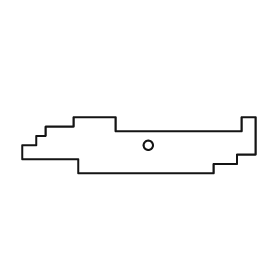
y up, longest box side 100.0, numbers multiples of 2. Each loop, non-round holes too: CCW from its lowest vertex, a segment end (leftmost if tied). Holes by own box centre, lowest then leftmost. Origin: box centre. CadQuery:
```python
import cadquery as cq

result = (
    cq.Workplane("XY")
    .moveTo(-26.0, -12.0)
    .lineTo(32.0, -12.0)
    .lineTo(32.0, -8.0)
    .lineTo(42.0, -8.0)
    .lineTo(42.0, -4.0)
    .lineTo(50.0, -4.0)
    .lineTo(50.0, 12.0)
    .lineTo(44.0, 12.0)
    .lineTo(44.0, 6.0)
    .lineTo(-10.0, 6.0)
    .lineTo(-10.0, 12.0)
    .lineTo(-28.0, 12.0)
    .lineTo(-28.0, 8.0)
    .lineTo(-40.0, 8.0)
    .lineTo(-40.0, 4.0)
    .lineTo(-44.0, 4.0)
    .lineTo(-44.0, 0.0)
    .lineTo(-50.0, 0.0)
    .lineTo(-50.0, -6.0)
    .lineTo(-26.0, -6.0)
    .close()
    .moveTo(4.0, 0.0)
    .circle(2.0)
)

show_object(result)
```